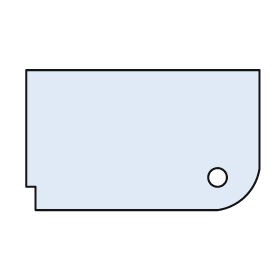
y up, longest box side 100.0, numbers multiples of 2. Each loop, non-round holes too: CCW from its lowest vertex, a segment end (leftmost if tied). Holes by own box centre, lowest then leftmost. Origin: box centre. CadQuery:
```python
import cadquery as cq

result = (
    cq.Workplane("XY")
    .moveTo(-46.0, -30.0)
    .lineTo(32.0, -30.0)
    .threePointArc((44.0, -24.0), (50.0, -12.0))
    .lineTo(50.0, 30.0)
    .lineTo(-50.0, 30.0)
    .lineTo(-50.0, -20.0)
    .lineTo(-46.0, -20.0)
    .close()
    .moveTo(32.0, -16.0)
    .circle(4.0)
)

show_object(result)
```